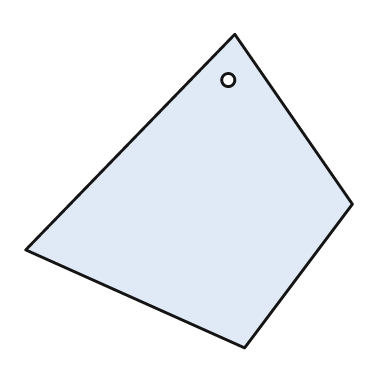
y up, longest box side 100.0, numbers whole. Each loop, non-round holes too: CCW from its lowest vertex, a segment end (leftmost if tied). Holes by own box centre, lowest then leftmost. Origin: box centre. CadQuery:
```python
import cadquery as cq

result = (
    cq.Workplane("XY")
    .moveTo(17.0, -48.0)
    .lineTo(50.0, -4.0)
    .lineTo(14.0, 48.0)
    .lineTo(-50.0, -18.0)
    .close()
    .moveTo(12.0, 34.0)
    .circle(2.0)
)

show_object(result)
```